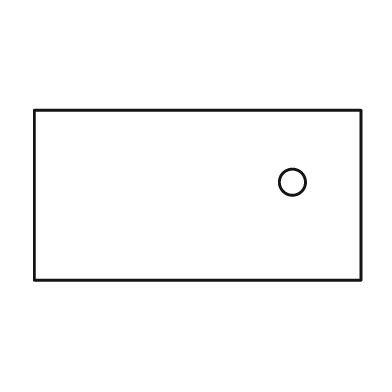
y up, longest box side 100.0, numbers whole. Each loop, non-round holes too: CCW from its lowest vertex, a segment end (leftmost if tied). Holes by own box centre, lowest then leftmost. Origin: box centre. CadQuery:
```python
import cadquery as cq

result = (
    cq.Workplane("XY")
    .moveTo(-50.0, -26.0)
    .lineTo(50.0, -26.0)
    .lineTo(50.0, 26.0)
    .lineTo(-50.0, 26.0)
    .close()
    .moveTo(29.0, 4.0)
    .circle(4.0)
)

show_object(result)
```